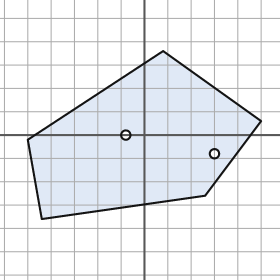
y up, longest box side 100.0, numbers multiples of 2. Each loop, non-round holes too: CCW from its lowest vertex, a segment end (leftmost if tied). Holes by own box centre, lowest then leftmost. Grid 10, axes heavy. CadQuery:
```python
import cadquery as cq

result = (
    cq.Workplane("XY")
    .moveTo(-44.0, -36.0)
    .lineTo(26.0, -26.0)
    .lineTo(50.0, 6.0)
    .lineTo(8.0, 36.0)
    .lineTo(-50.0, -2.0)
    .close()
    .moveTo(30.0, -8.0)
    .circle(2.0)
    .moveTo(-8.0, 0.0)
    .circle(2.0)
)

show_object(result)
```